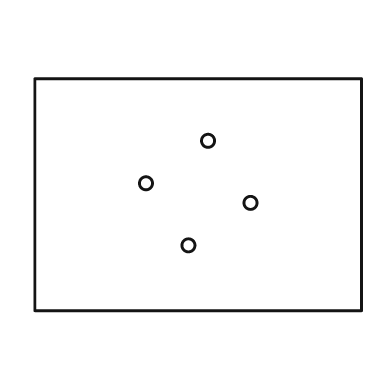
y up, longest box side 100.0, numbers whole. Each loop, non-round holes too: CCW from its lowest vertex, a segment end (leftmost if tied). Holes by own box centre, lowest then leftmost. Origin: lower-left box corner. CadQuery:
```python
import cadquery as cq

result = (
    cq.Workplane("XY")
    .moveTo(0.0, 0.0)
    .lineTo(100.0, 0.0)
    .lineTo(100.0, 71.0)
    .lineTo(0.0, 71.0)
    .close()
    .moveTo(47.0, 20.0)
    .circle(2.0)
    .moveTo(66.0, 33.0)
    .circle(2.0)
    .moveTo(34.0, 39.0)
    .circle(2.0)
    .moveTo(53.0, 52.0)
    .circle(2.0)
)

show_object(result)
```